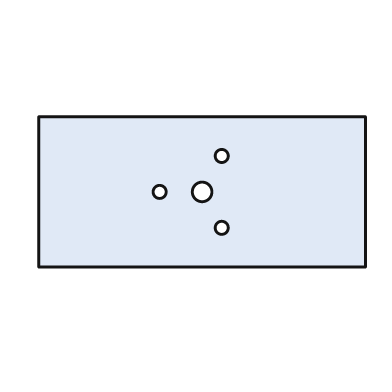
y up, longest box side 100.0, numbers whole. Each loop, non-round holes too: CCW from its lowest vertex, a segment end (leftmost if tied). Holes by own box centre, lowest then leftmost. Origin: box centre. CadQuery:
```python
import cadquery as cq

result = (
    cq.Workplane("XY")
    .moveTo(-50.0, -23.0)
    .lineTo(50.0, -23.0)
    .lineTo(50.0, 23.0)
    .lineTo(-50.0, 23.0)
    .close()
    .moveTo(6.0, -11.0)
    .circle(2.0)
    .moveTo(-13.0, 0.0)
    .circle(2.0)
    .moveTo(0.0, 0.0)
    .circle(3.0)
    .moveTo(6.0, 11.0)
    .circle(2.0)
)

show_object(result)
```